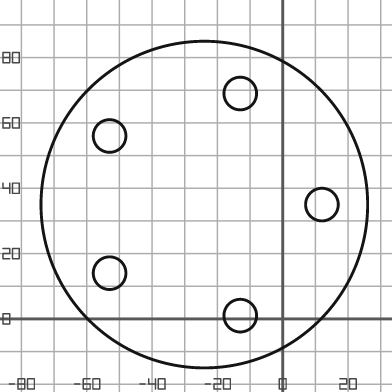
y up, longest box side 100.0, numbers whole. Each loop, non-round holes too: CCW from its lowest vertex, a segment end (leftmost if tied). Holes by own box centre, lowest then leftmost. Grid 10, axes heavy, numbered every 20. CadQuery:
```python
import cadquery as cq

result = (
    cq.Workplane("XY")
    .moveTo(-24.0, 35.0)
    .circle(50.0)
    .moveTo(-13.0, 1.0)
    .circle(5.0)
    .moveTo(-53.0, 14.0)
    .circle(5.0)
    .moveTo(12.0, 35.0)
    .circle(5.0)
    .moveTo(-53.0, 56.0)
    .circle(5.0)
    .moveTo(-13.0, 69.0)
    .circle(5.0)
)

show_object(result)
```